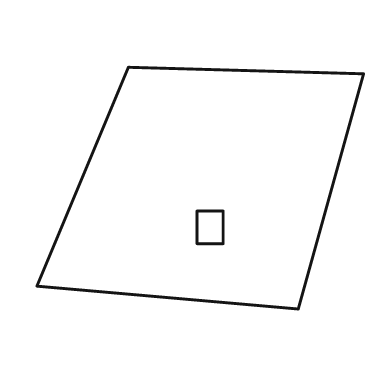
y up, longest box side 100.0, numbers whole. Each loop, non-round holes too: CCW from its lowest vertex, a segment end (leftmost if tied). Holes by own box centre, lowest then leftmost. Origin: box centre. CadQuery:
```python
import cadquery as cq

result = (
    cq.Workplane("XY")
    .moveTo(30.0, -37.0)
    .lineTo(50.0, 35.0)
    .lineTo(-22.0, 37.0)
    .lineTo(-50.0, -30.0)
    .close()
    .moveTo(-1.0, -17.0)
    .lineTo(7.0, -17.0)
    .lineTo(7.0, -7.0)
    .lineTo(-1.0, -7.0)
    .close()
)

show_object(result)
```